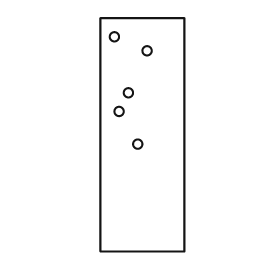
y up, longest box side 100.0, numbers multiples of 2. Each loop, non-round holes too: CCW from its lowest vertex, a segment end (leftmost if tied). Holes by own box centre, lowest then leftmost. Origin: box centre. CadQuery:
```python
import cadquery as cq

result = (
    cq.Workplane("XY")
    .moveTo(-18.0, -50.0)
    .lineTo(18.0, -50.0)
    .lineTo(18.0, 50.0)
    .lineTo(-18.0, 50.0)
    .close()
    .moveTo(-2.0, -4.0)
    .circle(2.0)
    .moveTo(-10.0, 10.0)
    .circle(2.0)
    .moveTo(-6.0, 18.0)
    .circle(2.0)
    .moveTo(2.0, 36.0)
    .circle(2.0)
    .moveTo(-12.0, 42.0)
    .circle(2.0)
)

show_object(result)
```